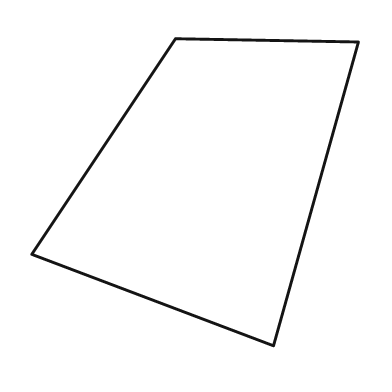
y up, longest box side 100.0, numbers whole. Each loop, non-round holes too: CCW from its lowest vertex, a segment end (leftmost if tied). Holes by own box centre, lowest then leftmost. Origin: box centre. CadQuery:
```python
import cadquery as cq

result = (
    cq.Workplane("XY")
    .moveTo(24.0, -47.0)
    .lineTo(50.0, 46.0)
    .lineTo(-6.0, 47.0)
    .lineTo(-50.0, -19.0)
    .close()
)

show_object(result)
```